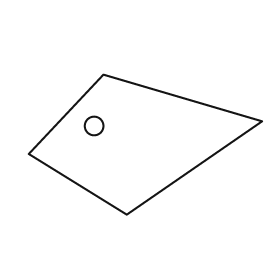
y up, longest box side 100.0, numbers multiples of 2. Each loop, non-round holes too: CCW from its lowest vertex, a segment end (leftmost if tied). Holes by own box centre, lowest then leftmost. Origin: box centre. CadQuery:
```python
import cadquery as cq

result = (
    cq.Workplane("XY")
    .moveTo(-8.0, -30.0)
    .lineTo(50.0, 10.0)
    .lineTo(-18.0, 30.0)
    .lineTo(-50.0, -4.0)
    .close()
    .moveTo(-22.0, 8.0)
    .circle(4.0)
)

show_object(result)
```